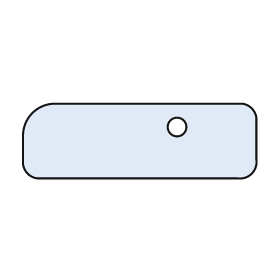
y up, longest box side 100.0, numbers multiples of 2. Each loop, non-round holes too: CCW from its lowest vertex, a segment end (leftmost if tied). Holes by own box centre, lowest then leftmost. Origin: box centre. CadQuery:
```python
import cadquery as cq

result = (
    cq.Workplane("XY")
    .moveTo(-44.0, -16.0)
    .lineTo(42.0, -16.0)
    .threePointArc((48.0, -14.0), (50.0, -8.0))
    .lineTo(50.0, 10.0)
    .threePointArc((48.0, 14.0), (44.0, 16.0))
    .lineTo(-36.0, 16.0)
    .threePointArc((-46.0, 12.0), (-50.0, 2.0))
    .lineTo(-50.0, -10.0)
    .threePointArc((-48.0, -14.0), (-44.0, -16.0))
    .close()
    .moveTo(16.0, 6.0)
    .circle(4.0)
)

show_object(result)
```